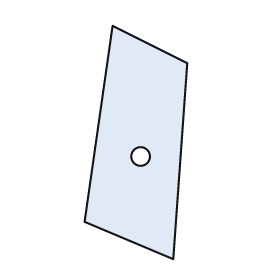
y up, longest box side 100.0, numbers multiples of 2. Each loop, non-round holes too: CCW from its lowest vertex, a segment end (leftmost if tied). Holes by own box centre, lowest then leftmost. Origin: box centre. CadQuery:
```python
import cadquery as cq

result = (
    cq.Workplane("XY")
    .moveTo(16.0, -50.0)
    .lineTo(22.0, 34.0)
    .lineTo(-10.0, 50.0)
    .lineTo(-22.0, -34.0)
    .close()
    .moveTo(2.0, -6.0)
    .circle(4.0)
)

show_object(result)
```